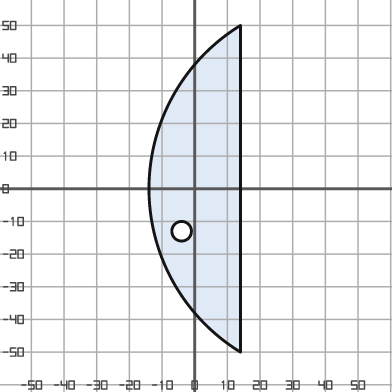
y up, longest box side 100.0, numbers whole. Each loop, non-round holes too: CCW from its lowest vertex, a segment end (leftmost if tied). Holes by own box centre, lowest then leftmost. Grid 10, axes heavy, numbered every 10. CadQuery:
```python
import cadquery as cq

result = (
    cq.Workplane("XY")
    .moveTo(14.0, -50.0)
    .lineTo(14.0, 50.0)
    .threePointArc((-14.0, 0.0), (14.0, -50.0))
    .close()
    .moveTo(-4.0, -13.0)
    .circle(3.0)
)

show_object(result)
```